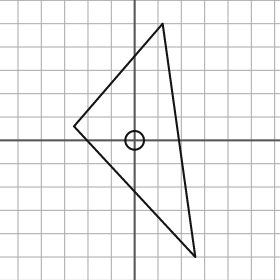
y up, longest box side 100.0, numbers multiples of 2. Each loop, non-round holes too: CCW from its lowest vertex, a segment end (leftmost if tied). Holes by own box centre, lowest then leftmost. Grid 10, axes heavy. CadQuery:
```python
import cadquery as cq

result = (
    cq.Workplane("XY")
    .moveTo(26.0, -50.0)
    .lineTo(12.0, 50.0)
    .lineTo(-26.0, 6.0)
    .close()
    .moveTo(0.0, 0.0)
    .circle(4.0)
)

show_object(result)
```